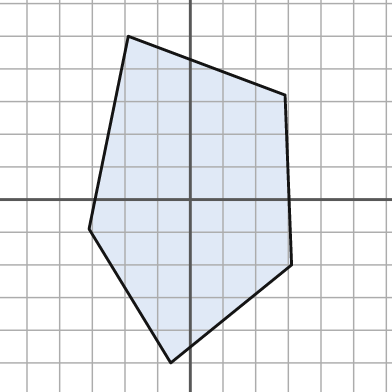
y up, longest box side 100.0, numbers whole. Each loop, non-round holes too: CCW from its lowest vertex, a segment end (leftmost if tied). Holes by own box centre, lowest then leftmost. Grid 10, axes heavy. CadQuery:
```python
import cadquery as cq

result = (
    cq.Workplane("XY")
    .moveTo(-6.0, -50.0)
    .lineTo(31.0, -20.0)
    .lineTo(29.0, 32.0)
    .lineTo(-19.0, 50.0)
    .lineTo(-31.0, -9.0)
    .close()
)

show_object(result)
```